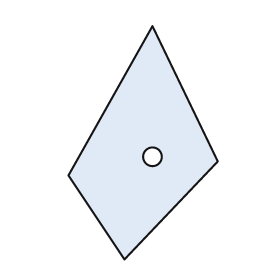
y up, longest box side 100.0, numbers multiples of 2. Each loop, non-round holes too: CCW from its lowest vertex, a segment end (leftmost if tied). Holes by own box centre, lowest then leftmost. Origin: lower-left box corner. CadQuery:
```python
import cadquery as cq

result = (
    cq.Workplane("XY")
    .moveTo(24.0, 0.0)
    .lineTo(64.0, 42.0)
    .lineTo(36.0, 100.0)
    .lineTo(0.0, 36.0)
    .close()
    .moveTo(36.0, 44.0)
    .circle(4.0)
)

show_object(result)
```